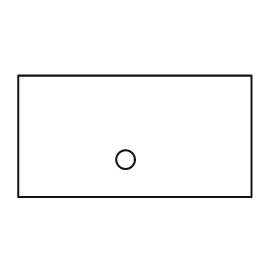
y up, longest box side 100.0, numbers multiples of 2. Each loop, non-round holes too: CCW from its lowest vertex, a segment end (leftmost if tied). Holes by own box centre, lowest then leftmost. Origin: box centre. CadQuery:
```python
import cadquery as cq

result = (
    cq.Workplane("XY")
    .moveTo(-50.0, -26.0)
    .lineTo(50.0, -26.0)
    .lineTo(50.0, 26.0)
    .lineTo(-50.0, 26.0)
    .close()
    .moveTo(-4.0, -10.0)
    .circle(4.0)
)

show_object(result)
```